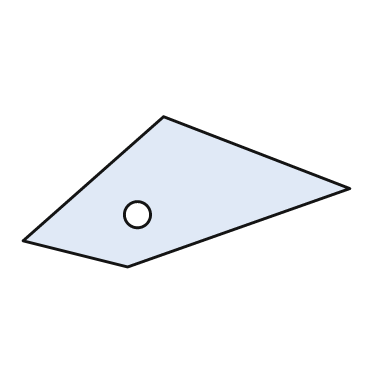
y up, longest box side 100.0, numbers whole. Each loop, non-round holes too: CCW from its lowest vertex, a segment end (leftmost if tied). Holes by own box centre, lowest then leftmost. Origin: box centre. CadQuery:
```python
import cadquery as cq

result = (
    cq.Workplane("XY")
    .moveTo(-18.0, -23.0)
    .lineTo(50.0, 1.0)
    .lineTo(-7.0, 23.0)
    .lineTo(-50.0, -15.0)
    .close()
    .moveTo(-15.0, -7.0)
    .circle(4.0)
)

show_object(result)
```